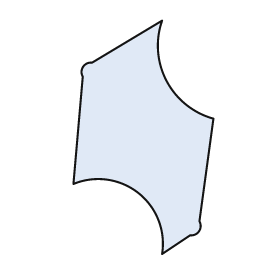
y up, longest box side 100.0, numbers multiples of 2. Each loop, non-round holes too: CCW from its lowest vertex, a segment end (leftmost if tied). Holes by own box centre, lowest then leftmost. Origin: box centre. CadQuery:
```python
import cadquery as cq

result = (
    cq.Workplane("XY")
    .moveTo(8.0, -50.0)
    .lineTo(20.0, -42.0)
    .threePointArc((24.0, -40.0), (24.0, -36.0))
    .lineTo(30.0, 8.0)
    .threePointArc((10.0, 24.0), (8.0, 50.0))
    .lineTo(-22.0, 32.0)
    .threePointArc((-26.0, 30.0), (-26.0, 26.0))
    .lineTo(-30.0, -20.0)
    .threePointArc((-2.0, -24.0), (8.0, -50.0))
    .close()
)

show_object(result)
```